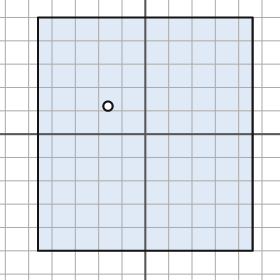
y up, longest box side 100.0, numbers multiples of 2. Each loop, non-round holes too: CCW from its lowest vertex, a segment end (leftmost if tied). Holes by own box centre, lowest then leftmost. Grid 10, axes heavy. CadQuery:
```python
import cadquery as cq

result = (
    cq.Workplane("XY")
    .moveTo(-46.0, -50.0)
    .lineTo(46.0, -50.0)
    .lineTo(46.0, 50.0)
    .lineTo(-46.0, 50.0)
    .close()
    .moveTo(-16.0, 12.0)
    .circle(2.0)
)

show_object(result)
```